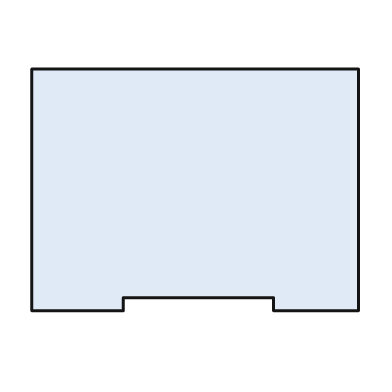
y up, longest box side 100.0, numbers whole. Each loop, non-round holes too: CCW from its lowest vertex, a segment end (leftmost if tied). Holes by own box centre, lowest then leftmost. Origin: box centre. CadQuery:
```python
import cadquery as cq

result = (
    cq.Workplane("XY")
    .moveTo(-50.0, -37.0)
    .lineTo(-22.0, -37.0)
    .lineTo(-22.0, -33.0)
    .lineTo(24.0, -33.0)
    .lineTo(24.0, -37.0)
    .lineTo(50.0, -37.0)
    .lineTo(50.0, 37.0)
    .lineTo(-50.0, 37.0)
    .close()
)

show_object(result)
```